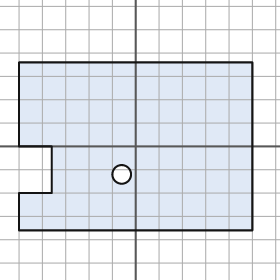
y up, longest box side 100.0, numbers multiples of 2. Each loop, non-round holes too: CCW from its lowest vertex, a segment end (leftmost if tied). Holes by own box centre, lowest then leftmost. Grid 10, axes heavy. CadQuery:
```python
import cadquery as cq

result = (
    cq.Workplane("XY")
    .moveTo(-50.0, -36.0)
    .lineTo(50.0, -36.0)
    .lineTo(50.0, 36.0)
    .lineTo(-50.0, 36.0)
    .lineTo(-50.0, 0.0)
    .lineTo(-36.0, 0.0)
    .lineTo(-36.0, -20.0)
    .lineTo(-50.0, -20.0)
    .close()
    .moveTo(-6.0, -12.0)
    .circle(4.0)
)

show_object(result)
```